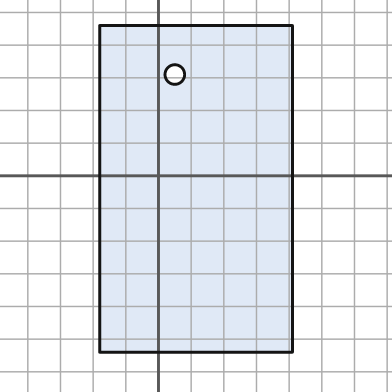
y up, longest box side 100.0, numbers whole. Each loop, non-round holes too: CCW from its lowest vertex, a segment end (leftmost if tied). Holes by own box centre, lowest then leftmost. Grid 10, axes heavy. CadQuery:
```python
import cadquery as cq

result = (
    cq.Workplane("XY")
    .moveTo(-18.0, -54.0)
    .lineTo(41.0, -54.0)
    .lineTo(41.0, 46.0)
    .lineTo(-18.0, 46.0)
    .close()
    .moveTo(5.0, 31.0)
    .circle(3.0)
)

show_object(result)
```